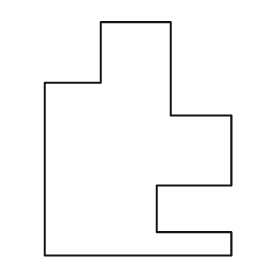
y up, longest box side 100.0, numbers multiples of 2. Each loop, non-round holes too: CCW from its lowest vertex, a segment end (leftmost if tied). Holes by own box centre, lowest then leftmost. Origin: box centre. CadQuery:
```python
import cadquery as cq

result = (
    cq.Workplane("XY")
    .moveTo(-40.0, -50.0)
    .lineTo(40.0, -50.0)
    .lineTo(40.0, -40.0)
    .lineTo(8.0, -40.0)
    .lineTo(8.0, -20.0)
    .lineTo(40.0, -20.0)
    .lineTo(40.0, 10.0)
    .lineTo(14.0, 10.0)
    .lineTo(14.0, 50.0)
    .lineTo(-16.0, 50.0)
    .lineTo(-16.0, 24.0)
    .lineTo(-40.0, 24.0)
    .close()
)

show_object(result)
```